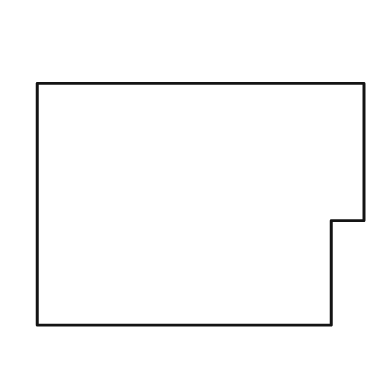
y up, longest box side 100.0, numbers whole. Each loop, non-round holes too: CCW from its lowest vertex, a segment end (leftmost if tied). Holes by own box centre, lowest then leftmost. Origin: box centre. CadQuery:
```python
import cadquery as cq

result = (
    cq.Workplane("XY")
    .moveTo(-50.0, -37.0)
    .lineTo(40.0, -37.0)
    .lineTo(40.0, -5.0)
    .lineTo(50.0, -5.0)
    .lineTo(50.0, 37.0)
    .lineTo(-50.0, 37.0)
    .close()
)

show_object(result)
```